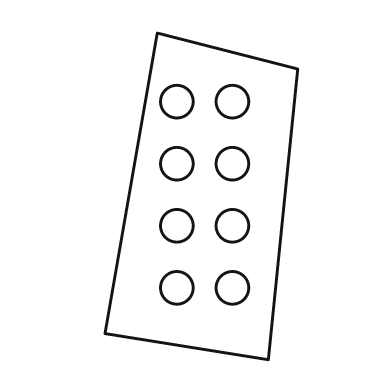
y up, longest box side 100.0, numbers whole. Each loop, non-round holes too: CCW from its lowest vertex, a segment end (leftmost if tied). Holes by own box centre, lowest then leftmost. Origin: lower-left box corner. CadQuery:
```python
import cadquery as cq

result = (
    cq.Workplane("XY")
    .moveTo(50.0, 0.0)
    .lineTo(59.0, 89.0)
    .lineTo(16.0, 100.0)
    .lineTo(0.0, 8.0)
    .close()
    .moveTo(22.0, 22.0)
    .circle(5.0)
    .moveTo(39.0, 22.0)
    .circle(5.0)
    .moveTo(22.0, 41.0)
    .circle(5.0)
    .moveTo(39.0, 41.0)
    .circle(5.0)
    .moveTo(22.0, 60.0)
    .circle(5.0)
    .moveTo(39.0, 60.0)
    .circle(5.0)
    .moveTo(22.0, 79.0)
    .circle(5.0)
    .moveTo(39.0, 79.0)
    .circle(5.0)
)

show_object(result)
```